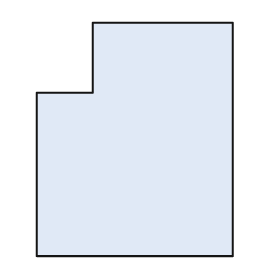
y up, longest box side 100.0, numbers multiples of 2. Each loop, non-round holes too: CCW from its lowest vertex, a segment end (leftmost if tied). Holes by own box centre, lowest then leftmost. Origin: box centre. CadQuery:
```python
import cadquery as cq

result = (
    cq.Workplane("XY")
    .moveTo(-42.0, -50.0)
    .lineTo(42.0, -50.0)
    .lineTo(42.0, 50.0)
    .lineTo(-18.0, 50.0)
    .lineTo(-18.0, 20.0)
    .lineTo(-42.0, 20.0)
    .close()
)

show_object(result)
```